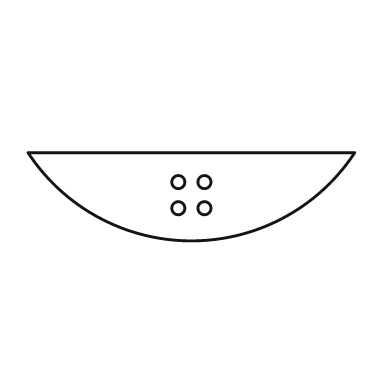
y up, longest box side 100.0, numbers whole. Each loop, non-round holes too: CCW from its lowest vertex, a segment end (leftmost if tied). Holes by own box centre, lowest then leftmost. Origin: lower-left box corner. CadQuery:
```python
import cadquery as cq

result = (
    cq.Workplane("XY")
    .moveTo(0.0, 27.0)
    .threePointArc((50.0, 0.0), (100.0, 27.0))
    .close()
    .moveTo(46.0, 10.0)
    .circle(2.0)
    .moveTo(54.0, 10.0)
    .circle(2.0)
    .moveTo(46.0, 18.0)
    .circle(2.0)
    .moveTo(54.0, 18.0)
    .circle(2.0)
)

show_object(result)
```